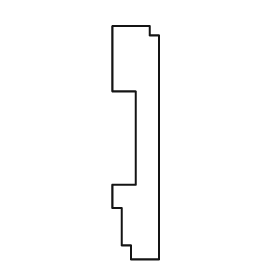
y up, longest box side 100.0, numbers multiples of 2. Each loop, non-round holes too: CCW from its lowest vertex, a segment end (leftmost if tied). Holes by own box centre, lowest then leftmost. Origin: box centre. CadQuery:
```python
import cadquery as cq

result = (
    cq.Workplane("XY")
    .moveTo(-2.0, -50.0)
    .lineTo(10.0, -50.0)
    .lineTo(10.0, 46.0)
    .lineTo(6.0, 46.0)
    .lineTo(6.0, 50.0)
    .lineTo(-10.0, 50.0)
    .lineTo(-10.0, 22.0)
    .lineTo(0.0, 22.0)
    .lineTo(0.0, -18.0)
    .lineTo(-10.0, -18.0)
    .lineTo(-10.0, -28.0)
    .lineTo(-6.0, -28.0)
    .lineTo(-6.0, -44.0)
    .lineTo(-2.0, -44.0)
    .close()
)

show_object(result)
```